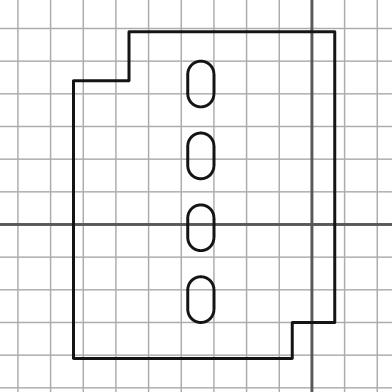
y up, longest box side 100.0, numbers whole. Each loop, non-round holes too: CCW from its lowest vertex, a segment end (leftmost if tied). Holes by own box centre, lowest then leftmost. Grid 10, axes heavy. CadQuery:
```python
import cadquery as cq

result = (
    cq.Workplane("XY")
    .moveTo(-73.0, -41.0)
    .lineTo(-6.0, -41.0)
    .lineTo(-6.0, -30.0)
    .lineTo(7.0, -30.0)
    .lineTo(7.0, 59.0)
    .lineTo(-56.0, 59.0)
    .lineTo(-56.0, 44.0)
    .lineTo(-73.0, 44.0)
    .close()
    .moveTo(-38.0, -26.0)
    .threePointArc((-34.0, -30.0), (-30.0, -26.0))
    .lineTo(-30.0, -20.0)
    .threePointArc((-34.0, -16.0), (-38.0, -20.0))
    .close()
    .moveTo(-38.0, -4.0)
    .threePointArc((-34.0, -8.0), (-30.0, -4.0))
    .lineTo(-30.0, 2.0)
    .threePointArc((-34.0, 6.0), (-38.0, 2.0))
    .close()
    .moveTo(-38.0, 18.0)
    .threePointArc((-34.0, 14.0), (-30.0, 18.0))
    .lineTo(-30.0, 24.0)
    .threePointArc((-34.0, 28.0), (-38.0, 24.0))
    .close()
    .moveTo(-38.0, 40.0)
    .threePointArc((-34.0, 36.0), (-30.0, 40.0))
    .lineTo(-30.0, 46.0)
    .threePointArc((-34.0, 50.0), (-38.0, 46.0))
    .close()
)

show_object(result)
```